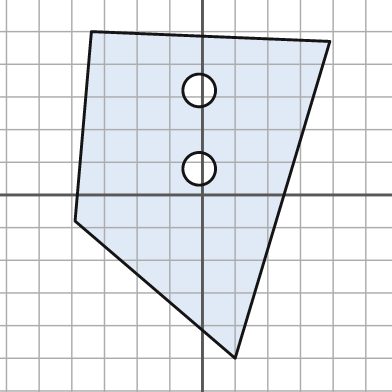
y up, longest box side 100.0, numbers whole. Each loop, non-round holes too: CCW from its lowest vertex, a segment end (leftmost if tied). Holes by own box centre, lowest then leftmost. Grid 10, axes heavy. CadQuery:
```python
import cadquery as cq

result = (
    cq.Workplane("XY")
    .moveTo(10.0, -50.0)
    .lineTo(39.0, 47.0)
    .lineTo(-34.0, 50.0)
    .lineTo(-39.0, -8.0)
    .close()
    .moveTo(-1.0, 8.0)
    .circle(5.0)
    .moveTo(-1.0, 32.0)
    .circle(5.0)
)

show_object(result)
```